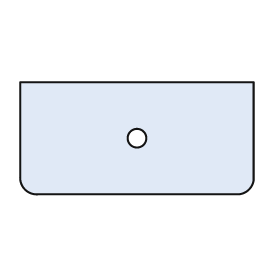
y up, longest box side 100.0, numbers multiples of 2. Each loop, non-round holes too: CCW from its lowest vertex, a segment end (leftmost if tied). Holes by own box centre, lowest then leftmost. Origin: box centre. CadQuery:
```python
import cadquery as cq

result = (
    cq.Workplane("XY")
    .moveTo(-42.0, -24.0)
    .lineTo(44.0, -24.0)
    .threePointArc((48.0, -22.0), (50.0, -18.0))
    .lineTo(50.0, 24.0)
    .lineTo(-50.0, 24.0)
    .lineTo(-50.0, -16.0)
    .threePointArc((-48.0, -22.0), (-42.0, -24.0))
    .close()
    .moveTo(0.0, 0.0)
    .circle(4.0)
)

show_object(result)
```